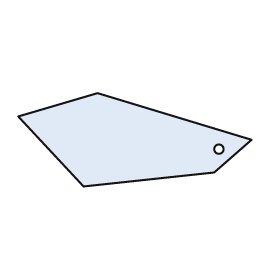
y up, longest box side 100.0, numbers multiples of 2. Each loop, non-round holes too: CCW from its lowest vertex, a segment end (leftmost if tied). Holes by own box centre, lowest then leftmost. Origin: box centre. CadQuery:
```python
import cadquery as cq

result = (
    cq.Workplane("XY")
    .moveTo(-22.0, -20.0)
    .lineTo(34.0, -14.0)
    .lineTo(50.0, 0.0)
    .lineTo(-16.0, 20.0)
    .lineTo(-50.0, 10.0)
    .close()
    .moveTo(36.0, -4.0)
    .circle(2.0)
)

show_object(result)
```